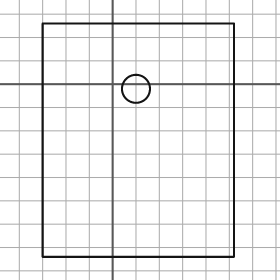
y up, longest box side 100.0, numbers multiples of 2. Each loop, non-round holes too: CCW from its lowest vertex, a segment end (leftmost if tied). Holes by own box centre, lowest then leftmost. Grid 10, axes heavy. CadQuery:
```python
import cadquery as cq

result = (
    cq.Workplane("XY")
    .moveTo(-30.0, -74.0)
    .lineTo(52.0, -74.0)
    .lineTo(52.0, 26.0)
    .lineTo(-30.0, 26.0)
    .close()
    .moveTo(10.0, -2.0)
    .circle(6.0)
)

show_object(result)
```